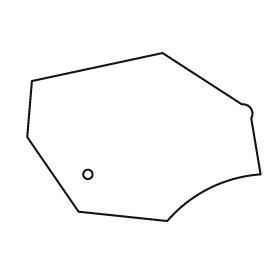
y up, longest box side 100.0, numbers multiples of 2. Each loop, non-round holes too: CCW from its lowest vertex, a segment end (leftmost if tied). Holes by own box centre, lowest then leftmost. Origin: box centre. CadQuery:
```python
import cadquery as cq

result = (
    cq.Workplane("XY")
    .moveTo(10.0, -36.0)
    .threePointArc((28.0, -22.0), (50.0, -16.0))
    .lineTo(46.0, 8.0)
    .threePointArc((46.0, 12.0), (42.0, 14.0))
    .lineTo(8.0, 36.0)
    .lineTo(-48.0, 24.0)
    .lineTo(-50.0, 0.0)
    .lineTo(-28.0, -32.0)
    .close()
    .moveTo(-24.0, -16.0)
    .circle(2.0)
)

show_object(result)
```